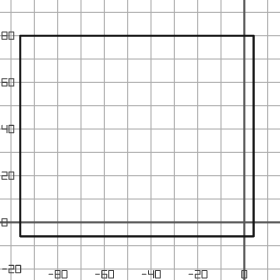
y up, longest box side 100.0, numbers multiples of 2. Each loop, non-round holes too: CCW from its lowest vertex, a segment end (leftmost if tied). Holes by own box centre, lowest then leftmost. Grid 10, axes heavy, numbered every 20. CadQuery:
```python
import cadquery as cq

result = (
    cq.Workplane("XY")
    .moveTo(-96.0, -6.0)
    .lineTo(4.0, -6.0)
    .lineTo(4.0, 80.0)
    .lineTo(-96.0, 80.0)
    .close()
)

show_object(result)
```